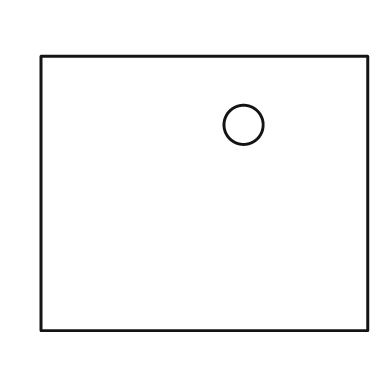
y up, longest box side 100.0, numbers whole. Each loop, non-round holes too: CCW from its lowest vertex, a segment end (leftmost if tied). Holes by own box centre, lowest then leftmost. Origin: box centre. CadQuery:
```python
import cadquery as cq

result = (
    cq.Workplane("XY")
    .moveTo(-50.0, -42.0)
    .lineTo(50.0, -42.0)
    .lineTo(50.0, 42.0)
    .lineTo(-50.0, 42.0)
    .close()
    .moveTo(12.0, 21.0)
    .circle(6.0)
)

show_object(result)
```